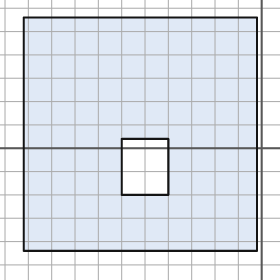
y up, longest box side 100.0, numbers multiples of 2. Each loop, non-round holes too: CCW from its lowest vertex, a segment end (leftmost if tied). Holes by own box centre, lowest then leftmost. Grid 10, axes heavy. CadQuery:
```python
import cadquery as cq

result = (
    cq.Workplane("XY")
    .moveTo(-102.0, -44.0)
    .lineTo(-2.0, -44.0)
    .lineTo(-2.0, 56.0)
    .lineTo(-102.0, 56.0)
    .close()
    .moveTo(-60.0, -20.0)
    .lineTo(-40.0, -20.0)
    .lineTo(-40.0, 4.0)
    .lineTo(-60.0, 4.0)
    .close()
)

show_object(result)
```